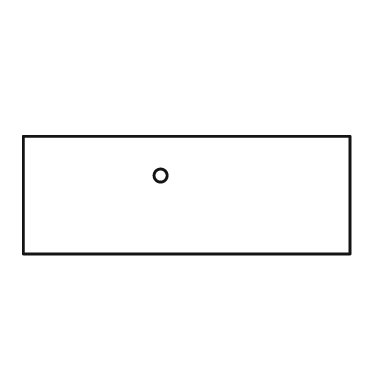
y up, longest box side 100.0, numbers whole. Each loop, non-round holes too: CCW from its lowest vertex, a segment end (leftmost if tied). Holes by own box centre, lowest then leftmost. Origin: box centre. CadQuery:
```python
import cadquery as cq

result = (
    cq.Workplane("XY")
    .moveTo(-50.0, -18.0)
    .lineTo(50.0, -18.0)
    .lineTo(50.0, 18.0)
    .lineTo(-50.0, 18.0)
    .close()
    .moveTo(-8.0, 6.0)
    .circle(2.0)
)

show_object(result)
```